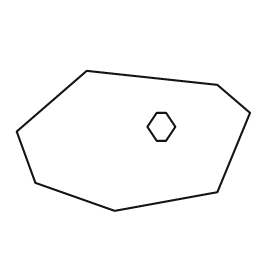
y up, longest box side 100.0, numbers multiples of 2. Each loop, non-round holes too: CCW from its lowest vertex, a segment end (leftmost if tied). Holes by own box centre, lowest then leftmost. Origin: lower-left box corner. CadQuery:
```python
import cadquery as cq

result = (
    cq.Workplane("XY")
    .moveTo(42.0, 0.0)
    .lineTo(86.0, 8.0)
    .lineTo(100.0, 42.0)
    .lineTo(86.0, 54.0)
    .lineTo(30.0, 60.0)
    .lineTo(0.0, 34.0)
    .lineTo(8.0, 12.0)
    .close()
    .moveTo(60.0, 30.0)
    .lineTo(64.0, 30.0)
    .lineTo(68.0, 36.0)
    .lineTo(64.0, 42.0)
    .lineTo(60.0, 42.0)
    .lineTo(56.0, 36.0)
    .close()
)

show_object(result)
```